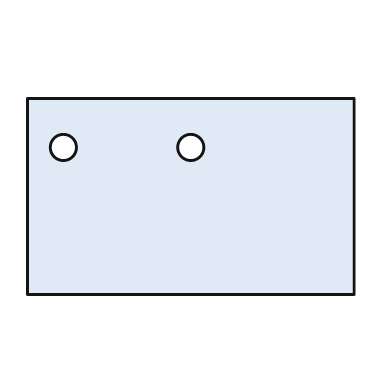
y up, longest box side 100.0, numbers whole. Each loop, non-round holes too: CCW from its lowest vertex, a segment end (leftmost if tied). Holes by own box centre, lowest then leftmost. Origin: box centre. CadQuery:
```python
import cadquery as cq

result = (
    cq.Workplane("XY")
    .moveTo(-50.0, -30.0)
    .lineTo(50.0, -30.0)
    .lineTo(50.0, 30.0)
    .lineTo(-50.0, 30.0)
    .close()
    .moveTo(-39.0, 15.0)
    .circle(4.0)
    .moveTo(0.0, 15.0)
    .circle(4.0)
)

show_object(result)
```